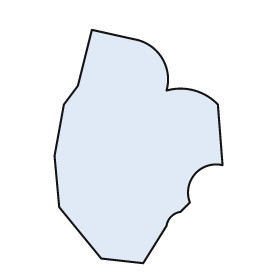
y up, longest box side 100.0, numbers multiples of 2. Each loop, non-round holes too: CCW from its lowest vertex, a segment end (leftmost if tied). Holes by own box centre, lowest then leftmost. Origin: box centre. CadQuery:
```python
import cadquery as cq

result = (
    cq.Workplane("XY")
    .moveTo(2.0, -50.0)
    .lineTo(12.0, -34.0)
    .threePointArc((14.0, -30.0), (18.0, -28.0))
    .lineTo(22.0, -24.0)
    .threePointArc((24.0, -12.0), (36.0, -8.0))
    .lineTo(34.0, 18.0)
    .threePointArc((24.0, 24.0), (12.0, 24.0))
    .threePointArc((10.0, 38.0), (-2.0, 46.0))
    .lineTo(-20.0, 50.0)
    .lineTo(-26.0, 26.0)
    .lineTo(-32.0, 18.0)
    .lineTo(-36.0, -4.0)
    .lineTo(-34.0, -26.0)
    .lineTo(-16.0, -48.0)
    .close()
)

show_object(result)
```